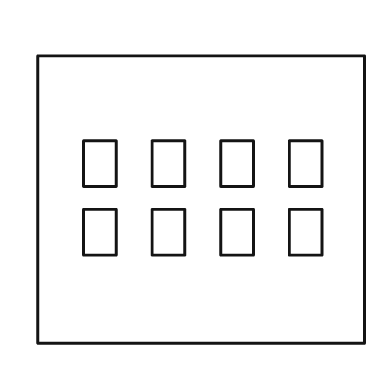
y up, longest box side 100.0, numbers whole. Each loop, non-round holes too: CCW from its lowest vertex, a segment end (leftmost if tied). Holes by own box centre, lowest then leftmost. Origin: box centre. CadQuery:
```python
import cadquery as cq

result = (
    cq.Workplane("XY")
    .moveTo(-50.0, -44.0)
    .lineTo(50.0, -44.0)
    .lineTo(50.0, 44.0)
    .lineTo(-50.0, 44.0)
    .close()
    .moveTo(-36.0, -17.0)
    .lineTo(-26.0, -17.0)
    .lineTo(-26.0, -3.0)
    .lineTo(-36.0, -3.0)
    .close()
    .moveTo(-15.0, -17.0)
    .lineTo(-5.0, -17.0)
    .lineTo(-5.0, -3.0)
    .lineTo(-15.0, -3.0)
    .close()
    .moveTo(6.0, -17.0)
    .lineTo(16.0, -17.0)
    .lineTo(16.0, -3.0)
    .lineTo(6.0, -3.0)
    .close()
    .moveTo(27.0, -17.0)
    .lineTo(37.0, -17.0)
    .lineTo(37.0, -3.0)
    .lineTo(27.0, -3.0)
    .close()
    .moveTo(-36.0, 4.0)
    .lineTo(-26.0, 4.0)
    .lineTo(-26.0, 18.0)
    .lineTo(-36.0, 18.0)
    .close()
    .moveTo(-15.0, 4.0)
    .lineTo(-5.0, 4.0)
    .lineTo(-5.0, 18.0)
    .lineTo(-15.0, 18.0)
    .close()
    .moveTo(6.0, 4.0)
    .lineTo(16.0, 4.0)
    .lineTo(16.0, 18.0)
    .lineTo(6.0, 18.0)
    .close()
    .moveTo(27.0, 4.0)
    .lineTo(37.0, 4.0)
    .lineTo(37.0, 18.0)
    .lineTo(27.0, 18.0)
    .close()
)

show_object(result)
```